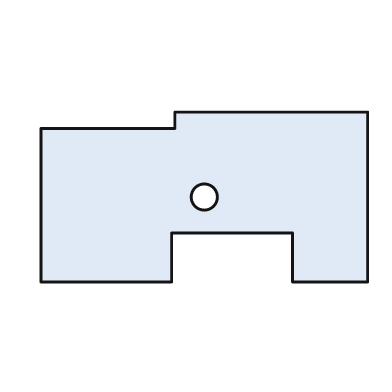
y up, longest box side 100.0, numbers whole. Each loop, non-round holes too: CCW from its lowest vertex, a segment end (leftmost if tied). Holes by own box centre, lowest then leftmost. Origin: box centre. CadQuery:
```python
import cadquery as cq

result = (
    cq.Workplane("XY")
    .moveTo(-50.0, -26.0)
    .lineTo(-10.0, -26.0)
    .lineTo(-10.0, -11.0)
    .lineTo(27.0, -11.0)
    .lineTo(27.0, -26.0)
    .lineTo(50.0, -26.0)
    .lineTo(50.0, 26.0)
    .lineTo(-9.0, 26.0)
    .lineTo(-9.0, 21.0)
    .lineTo(-50.0, 21.0)
    .close()
    .moveTo(0.0, 0.0)
    .circle(4.0)
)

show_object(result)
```